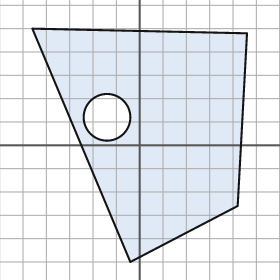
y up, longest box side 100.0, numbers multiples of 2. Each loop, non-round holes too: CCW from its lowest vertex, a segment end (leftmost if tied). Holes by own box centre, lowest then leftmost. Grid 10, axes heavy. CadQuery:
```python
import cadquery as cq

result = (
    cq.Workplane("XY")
    .moveTo(-4.0, -50.0)
    .lineTo(42.0, -26.0)
    .lineTo(46.0, 48.0)
    .lineTo(-46.0, 50.0)
    .close()
    .moveTo(-14.0, 12.0)
    .circle(10.0)
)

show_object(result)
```